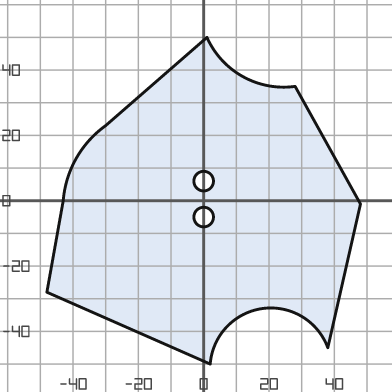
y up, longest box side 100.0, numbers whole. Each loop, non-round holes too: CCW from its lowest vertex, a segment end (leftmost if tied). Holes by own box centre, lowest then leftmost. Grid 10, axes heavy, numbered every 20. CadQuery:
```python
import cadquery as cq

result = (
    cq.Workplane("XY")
    .moveTo(2.0, -50.0)
    .threePointArc((18.0, -33.0), (38.0, -45.0))
    .lineTo(48.0, -1.0)
    .lineTo(28.0, 35.0)
    .threePointArc((12.0, 38.0), (1.0, 50.0))
    .lineTo(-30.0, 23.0)
    .threePointArc((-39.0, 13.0), (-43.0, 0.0))
    .lineTo(-48.0, -28.0)
    .close()
    .moveTo(0.0, -5.0)
    .circle(3.0)
    .moveTo(0.0, 6.0)
    .circle(3.0)
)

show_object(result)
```